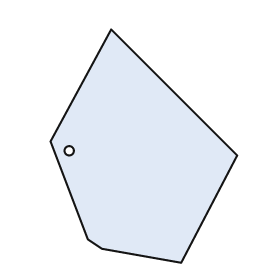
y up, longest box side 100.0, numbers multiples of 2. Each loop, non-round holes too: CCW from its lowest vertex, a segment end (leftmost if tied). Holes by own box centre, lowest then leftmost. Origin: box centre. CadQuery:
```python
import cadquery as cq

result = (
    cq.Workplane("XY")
    .moveTo(16.0, -50.0)
    .lineTo(40.0, -4.0)
    .lineTo(-14.0, 50.0)
    .lineTo(-40.0, 2.0)
    .lineTo(-24.0, -40.0)
    .lineTo(-18.0, -44.0)
    .close()
    .moveTo(-32.0, -2.0)
    .circle(2.0)
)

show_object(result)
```